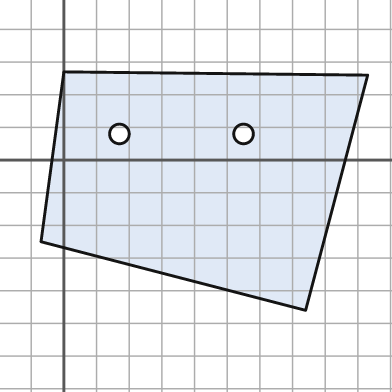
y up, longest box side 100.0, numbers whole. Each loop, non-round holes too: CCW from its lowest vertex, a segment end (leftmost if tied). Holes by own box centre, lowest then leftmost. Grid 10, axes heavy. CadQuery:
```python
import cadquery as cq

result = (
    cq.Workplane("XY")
    .moveTo(74.0, -46.0)
    .lineTo(93.0, 26.0)
    .lineTo(0.0, 27.0)
    .lineTo(-7.0, -25.0)
    .close()
    .moveTo(17.0, 8.0)
    .circle(3.0)
    .moveTo(55.0, 8.0)
    .circle(3.0)
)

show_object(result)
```